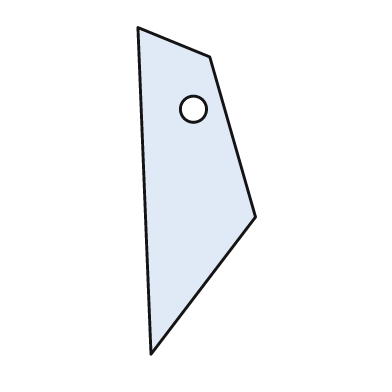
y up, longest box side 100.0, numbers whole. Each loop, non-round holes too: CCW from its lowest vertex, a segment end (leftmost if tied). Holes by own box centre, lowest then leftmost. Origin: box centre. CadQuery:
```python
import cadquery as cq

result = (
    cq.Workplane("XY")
    .moveTo(-14.0, -50.0)
    .lineTo(18.0, -8.0)
    .lineTo(4.0, 41.0)
    .lineTo(-18.0, 50.0)
    .close()
    .moveTo(-1.0, 25.0)
    .circle(4.0)
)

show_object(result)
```